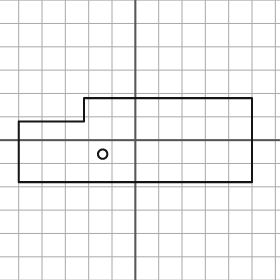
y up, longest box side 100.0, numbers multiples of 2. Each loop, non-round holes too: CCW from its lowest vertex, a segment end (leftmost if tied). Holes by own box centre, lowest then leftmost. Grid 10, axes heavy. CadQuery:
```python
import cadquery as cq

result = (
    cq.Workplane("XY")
    .moveTo(-50.0, -18.0)
    .lineTo(50.0, -18.0)
    .lineTo(50.0, 18.0)
    .lineTo(-22.0, 18.0)
    .lineTo(-22.0, 8.0)
    .lineTo(-50.0, 8.0)
    .close()
    .moveTo(-14.0, -6.0)
    .circle(2.0)
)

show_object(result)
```